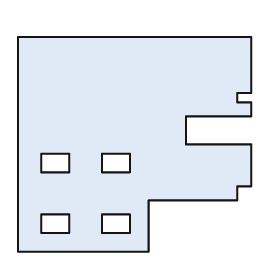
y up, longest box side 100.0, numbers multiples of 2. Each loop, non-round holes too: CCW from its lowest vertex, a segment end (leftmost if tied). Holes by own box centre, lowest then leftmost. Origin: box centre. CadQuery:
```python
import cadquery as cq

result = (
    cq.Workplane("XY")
    .moveTo(-50.0, -46.0)
    .lineTo(6.0, -46.0)
    .lineTo(6.0, -24.0)
    .lineTo(44.0, -24.0)
    .lineTo(44.0, -18.0)
    .lineTo(50.0, -18.0)
    .lineTo(50.0, 0.0)
    .lineTo(22.0, 0.0)
    .lineTo(22.0, 12.0)
    .lineTo(50.0, 12.0)
    .lineTo(50.0, 18.0)
    .lineTo(44.0, 18.0)
    .lineTo(44.0, 22.0)
    .lineTo(50.0, 22.0)
    .lineTo(50.0, 46.0)
    .lineTo(-50.0, 46.0)
    .close()
    .moveTo(-40.0, -38.0)
    .lineTo(-28.0, -38.0)
    .lineTo(-28.0, -30.0)
    .lineTo(-40.0, -30.0)
    .close()
    .moveTo(-14.0, -38.0)
    .lineTo(-2.0, -38.0)
    .lineTo(-2.0, -30.0)
    .lineTo(-14.0, -30.0)
    .close()
    .moveTo(-40.0, -12.0)
    .lineTo(-28.0, -12.0)
    .lineTo(-28.0, -4.0)
    .lineTo(-40.0, -4.0)
    .close()
    .moveTo(-14.0, -12.0)
    .lineTo(-2.0, -12.0)
    .lineTo(-2.0, -4.0)
    .lineTo(-14.0, -4.0)
    .close()
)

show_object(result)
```